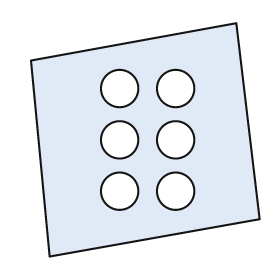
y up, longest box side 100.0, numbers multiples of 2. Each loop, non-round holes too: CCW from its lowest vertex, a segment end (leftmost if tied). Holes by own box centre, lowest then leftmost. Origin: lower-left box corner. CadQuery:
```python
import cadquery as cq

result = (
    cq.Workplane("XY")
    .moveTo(8.0, 0.0)
    .lineTo(98.0, 16.0)
    .lineTo(88.0, 100.0)
    .lineTo(0.0, 84.0)
    .close()
    .moveTo(38.0, 28.0)
    .circle(8.0)
    .moveTo(62.0, 28.0)
    .circle(8.0)
    .moveTo(38.0, 50.0)
    .circle(8.0)
    .moveTo(62.0, 50.0)
    .circle(8.0)
    .moveTo(38.0, 72.0)
    .circle(8.0)
    .moveTo(62.0, 72.0)
    .circle(8.0)
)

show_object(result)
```